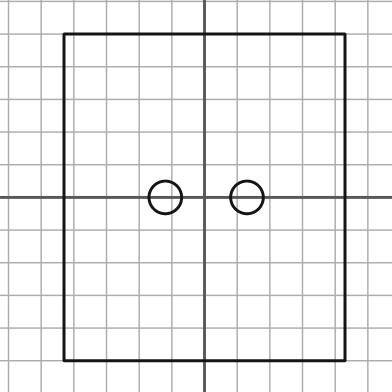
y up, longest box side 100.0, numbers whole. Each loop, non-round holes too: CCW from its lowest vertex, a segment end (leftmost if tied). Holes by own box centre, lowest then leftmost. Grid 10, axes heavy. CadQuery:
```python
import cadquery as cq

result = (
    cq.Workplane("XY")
    .moveTo(-43.0, -50.0)
    .lineTo(43.0, -50.0)
    .lineTo(43.0, 50.0)
    .lineTo(-43.0, 50.0)
    .close()
    .moveTo(-12.0, 0.0)
    .circle(5.0)
    .moveTo(13.0, 0.0)
    .circle(5.0)
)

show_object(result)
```